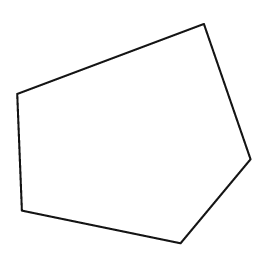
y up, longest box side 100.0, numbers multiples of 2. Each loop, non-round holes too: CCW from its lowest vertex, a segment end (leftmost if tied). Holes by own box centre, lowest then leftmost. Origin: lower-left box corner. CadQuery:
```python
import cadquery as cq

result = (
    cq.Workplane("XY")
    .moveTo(70.0, 0.0)
    .lineTo(100.0, 36.0)
    .lineTo(80.0, 94.0)
    .lineTo(0.0, 64.0)
    .lineTo(2.0, 14.0)
    .close()
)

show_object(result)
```